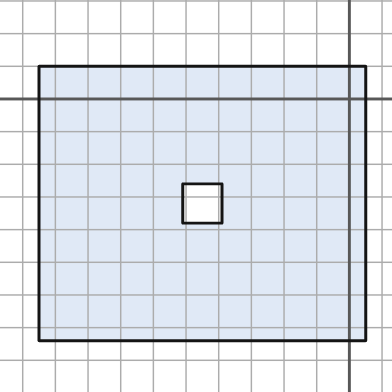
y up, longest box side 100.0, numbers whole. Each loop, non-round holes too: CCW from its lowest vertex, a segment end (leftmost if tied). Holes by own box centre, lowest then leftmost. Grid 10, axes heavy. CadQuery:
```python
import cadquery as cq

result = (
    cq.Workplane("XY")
    .moveTo(-95.0, -74.0)
    .lineTo(5.0, -74.0)
    .lineTo(5.0, 10.0)
    .lineTo(-95.0, 10.0)
    .close()
    .moveTo(-51.0, -38.0)
    .lineTo(-39.0, -38.0)
    .lineTo(-39.0, -26.0)
    .lineTo(-51.0, -26.0)
    .close()
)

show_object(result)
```